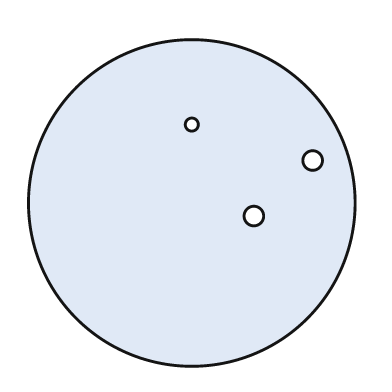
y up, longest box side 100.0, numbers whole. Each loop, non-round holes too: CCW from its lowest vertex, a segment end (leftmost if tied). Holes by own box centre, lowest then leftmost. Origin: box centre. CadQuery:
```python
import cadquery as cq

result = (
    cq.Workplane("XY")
    .moveTo(0.0, 0.0)
    .circle(50.0)
    .moveTo(19.0, -4.0)
    .circle(3.0)
    .moveTo(37.0, 13.0)
    .circle(3.0)
    .moveTo(0.0, 24.0)
    .circle(2.0)
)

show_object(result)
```